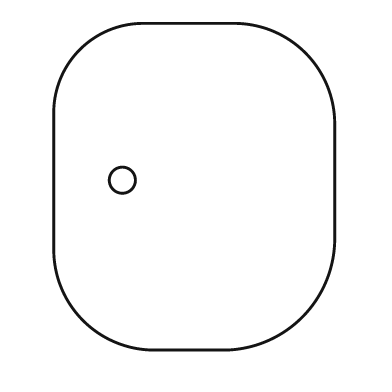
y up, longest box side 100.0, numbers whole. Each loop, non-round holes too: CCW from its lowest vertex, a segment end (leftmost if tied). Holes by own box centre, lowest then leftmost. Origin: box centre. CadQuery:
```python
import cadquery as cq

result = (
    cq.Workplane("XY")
    .moveTo(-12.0, -50.0)
    .lineTo(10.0, -50.0)
    .threePointArc((33.0, -40.0), (43.0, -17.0))
    .lineTo(43.0, 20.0)
    .threePointArc((34.0, 41.0), (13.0, 50.0))
    .lineTo(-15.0, 50.0)
    .threePointArc((-35.0, 42.0), (-43.0, 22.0))
    .lineTo(-43.0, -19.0)
    .threePointArc((-34.0, -41.0), (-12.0, -50.0))
    .close()
    .moveTo(-22.0, 2.0)
    .circle(4.0)
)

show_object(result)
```